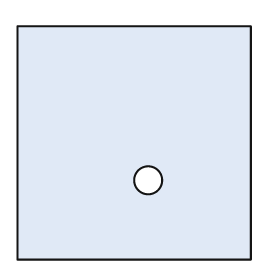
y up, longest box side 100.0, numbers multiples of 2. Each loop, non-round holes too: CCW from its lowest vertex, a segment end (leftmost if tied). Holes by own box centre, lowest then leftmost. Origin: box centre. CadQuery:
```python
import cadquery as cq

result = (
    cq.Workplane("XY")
    .moveTo(-50.0, -50.0)
    .lineTo(50.0, -50.0)
    .lineTo(50.0, 50.0)
    .lineTo(-50.0, 50.0)
    .close()
    .moveTo(6.0, -16.0)
    .circle(6.0)
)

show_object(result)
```